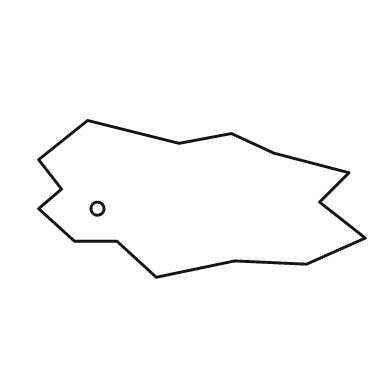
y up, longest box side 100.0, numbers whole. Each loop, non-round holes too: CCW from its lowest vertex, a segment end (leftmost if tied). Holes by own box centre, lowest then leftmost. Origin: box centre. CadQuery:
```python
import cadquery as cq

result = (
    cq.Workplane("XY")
    .moveTo(-14.0, -24.0)
    .lineTo(10.0, -19.0)
    .lineTo(32.0, -20.0)
    .lineTo(50.0, -12.0)
    .lineTo(36.0, -1.0)
    .lineTo(45.0, 8.0)
    .lineTo(22.0, 14.0)
    .lineTo(9.0, 20.0)
    .lineTo(-7.0, 17.0)
    .lineTo(-35.0, 24.0)
    .lineTo(-50.0, 12.0)
    .lineTo(-43.0, 3.0)
    .lineTo(-50.0, -3.0)
    .lineTo(-39.0, -13.0)
    .lineTo(-26.0, -13.0)
    .close()
    .moveTo(-32.0, -3.0)
    .circle(2.0)
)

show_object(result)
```